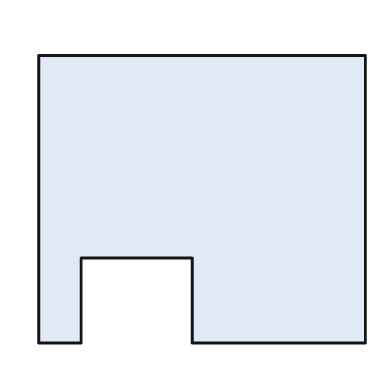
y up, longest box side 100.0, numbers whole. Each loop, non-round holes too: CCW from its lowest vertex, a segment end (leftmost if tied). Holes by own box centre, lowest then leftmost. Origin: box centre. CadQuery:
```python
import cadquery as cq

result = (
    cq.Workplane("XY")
    .moveTo(-50.0, -44.0)
    .lineTo(-37.0, -44.0)
    .lineTo(-37.0, -18.0)
    .lineTo(-3.0, -18.0)
    .lineTo(-3.0, -44.0)
    .lineTo(50.0, -44.0)
    .lineTo(50.0, 44.0)
    .lineTo(-50.0, 44.0)
    .close()
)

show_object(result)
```